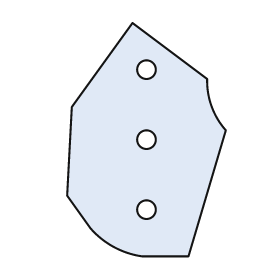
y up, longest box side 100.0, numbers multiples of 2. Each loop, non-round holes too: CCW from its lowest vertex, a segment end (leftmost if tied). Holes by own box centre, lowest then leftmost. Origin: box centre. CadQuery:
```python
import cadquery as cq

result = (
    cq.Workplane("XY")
    .moveTo(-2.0, -50.0)
    .lineTo(18.0, -50.0)
    .lineTo(34.0, 4.0)
    .threePointArc((28.0, 14.0), (26.0, 26.0))
    .lineTo(-6.0, 50.0)
    .lineTo(-32.0, 14.0)
    .lineTo(-34.0, -24.0)
    .lineTo(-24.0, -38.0)
    .threePointArc((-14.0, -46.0), (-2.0, -50.0))
    .close()
    .moveTo(0.0, -30.0)
    .circle(4.0)
    .moveTo(0.0, 0.0)
    .circle(4.0)
    .moveTo(0.0, 30.0)
    .circle(4.0)
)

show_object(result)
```